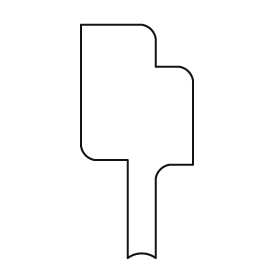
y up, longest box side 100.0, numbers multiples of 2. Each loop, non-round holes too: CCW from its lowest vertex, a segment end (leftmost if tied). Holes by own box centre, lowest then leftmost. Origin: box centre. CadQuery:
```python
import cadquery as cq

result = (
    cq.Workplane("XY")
    .moveTo(-4.0, -50.0)
    .threePointArc((2.0, -48.0), (8.0, -50.0))
    .lineTo(8.0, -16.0)
    .threePointArc((10.0, -12.0), (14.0, -10.0))
    .lineTo(24.0, -10.0)
    .lineTo(24.0, 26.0)
    .threePointArc((22.0, 30.0), (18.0, 32.0))
    .lineTo(8.0, 32.0)
    .lineTo(8.0, 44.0)
    .threePointArc((6.0, 48.0), (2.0, 50.0))
    .lineTo(-24.0, 50.0)
    .lineTo(-24.0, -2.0)
    .threePointArc((-22.0, -6.0), (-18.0, -8.0))
    .lineTo(-4.0, -8.0)
    .close()
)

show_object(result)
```